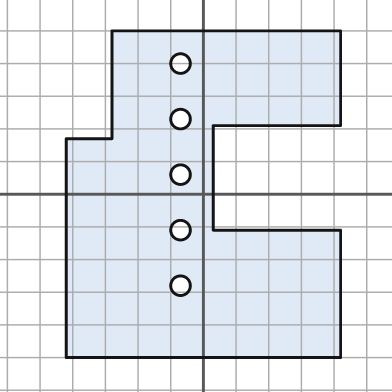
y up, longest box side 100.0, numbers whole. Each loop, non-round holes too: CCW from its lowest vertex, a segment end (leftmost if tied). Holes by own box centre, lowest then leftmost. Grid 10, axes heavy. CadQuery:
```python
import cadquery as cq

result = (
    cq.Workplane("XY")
    .moveTo(-42.0, -50.0)
    .lineTo(42.0, -50.0)
    .lineTo(42.0, -11.0)
    .lineTo(3.0, -11.0)
    .lineTo(3.0, 21.0)
    .lineTo(42.0, 21.0)
    .lineTo(42.0, 50.0)
    .lineTo(-28.0, 50.0)
    .lineTo(-28.0, 17.0)
    .lineTo(-42.0, 17.0)
    .close()
    .moveTo(-7.0, -28.0)
    .circle(3.0)
    .moveTo(-7.0, -11.0)
    .circle(3.0)
    .moveTo(-7.0, 6.0)
    .circle(3.0)
    .moveTo(-7.0, 23.0)
    .circle(3.0)
    .moveTo(-7.0, 40.0)
    .circle(3.0)
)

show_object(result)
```